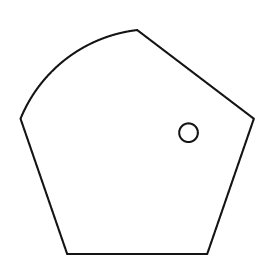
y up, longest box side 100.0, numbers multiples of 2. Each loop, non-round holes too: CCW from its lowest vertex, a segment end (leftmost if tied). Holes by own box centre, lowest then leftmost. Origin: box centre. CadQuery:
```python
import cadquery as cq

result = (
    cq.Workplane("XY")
    .moveTo(-30.0, -48.0)
    .lineTo(30.0, -48.0)
    .lineTo(50.0, 10.0)
    .lineTo(0.0, 48.0)
    .threePointArc((-30.0, 36.0), (-50.0, 10.0))
    .close()
    .moveTo(22.0, 4.0)
    .circle(4.0)
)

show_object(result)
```